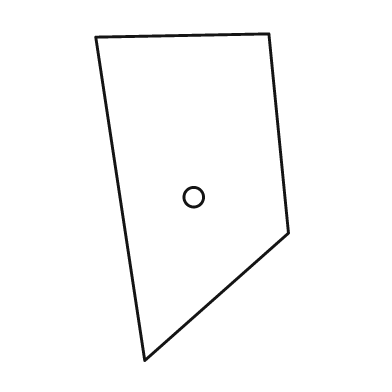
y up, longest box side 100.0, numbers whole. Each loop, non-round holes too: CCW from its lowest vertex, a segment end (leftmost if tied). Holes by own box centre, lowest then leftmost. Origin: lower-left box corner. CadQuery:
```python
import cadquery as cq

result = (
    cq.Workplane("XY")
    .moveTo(15.0, 0.0)
    .lineTo(59.0, 39.0)
    .lineTo(53.0, 100.0)
    .lineTo(0.0, 99.0)
    .close()
    .moveTo(30.0, 50.0)
    .circle(3.0)
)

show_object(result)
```